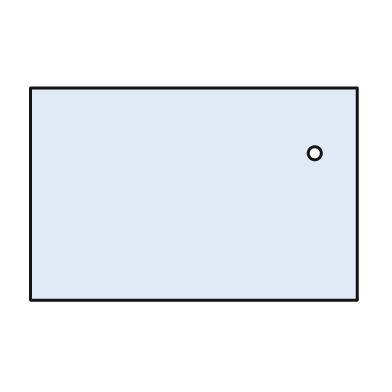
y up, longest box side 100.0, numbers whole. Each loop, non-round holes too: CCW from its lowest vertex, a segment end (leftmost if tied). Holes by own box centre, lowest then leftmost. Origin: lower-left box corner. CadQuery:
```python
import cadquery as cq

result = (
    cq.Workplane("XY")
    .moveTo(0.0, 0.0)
    .lineTo(100.0, 0.0)
    .lineTo(100.0, 65.0)
    .lineTo(0.0, 65.0)
    .close()
    .moveTo(87.0, 45.0)
    .circle(2.0)
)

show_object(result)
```